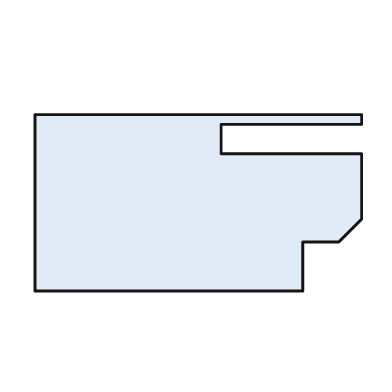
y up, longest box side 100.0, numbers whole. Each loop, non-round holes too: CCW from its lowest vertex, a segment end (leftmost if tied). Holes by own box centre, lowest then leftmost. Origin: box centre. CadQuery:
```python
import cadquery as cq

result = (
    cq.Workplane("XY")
    .moveTo(-50.0, -27.0)
    .lineTo(32.0, -27.0)
    .lineTo(32.0, -12.0)
    .lineTo(43.0, -12.0)
    .lineTo(50.0, -5.0)
    .lineTo(50.0, 15.0)
    .lineTo(7.0, 15.0)
    .lineTo(7.0, 24.0)
    .lineTo(50.0, 24.0)
    .lineTo(50.0, 27.0)
    .lineTo(-50.0, 27.0)
    .close()
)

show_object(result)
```